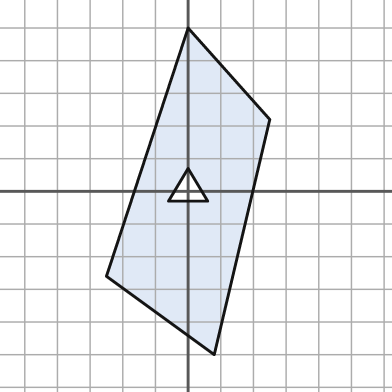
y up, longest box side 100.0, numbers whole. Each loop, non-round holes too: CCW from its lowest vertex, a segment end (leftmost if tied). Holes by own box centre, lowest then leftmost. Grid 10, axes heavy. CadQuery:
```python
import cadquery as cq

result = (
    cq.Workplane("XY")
    .moveTo(8.0, -50.0)
    .lineTo(25.0, 22.0)
    .lineTo(0.0, 50.0)
    .lineTo(-25.0, -26.0)
    .close()
    .moveTo(-6.0, -3.0)
    .lineTo(6.0, -3.0)
    .lineTo(0.0, 7.0)
    .close()
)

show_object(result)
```